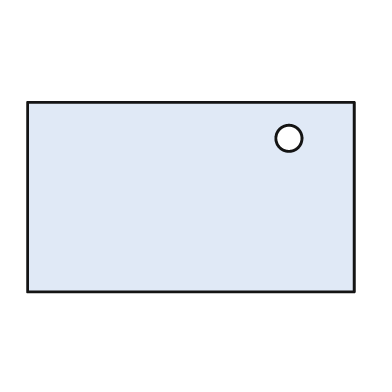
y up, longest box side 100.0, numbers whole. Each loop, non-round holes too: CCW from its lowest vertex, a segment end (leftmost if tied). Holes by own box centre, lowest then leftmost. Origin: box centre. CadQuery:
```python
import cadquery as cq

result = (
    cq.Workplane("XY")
    .moveTo(-50.0, -29.0)
    .lineTo(50.0, -29.0)
    .lineTo(50.0, 29.0)
    .lineTo(-50.0, 29.0)
    .close()
    .moveTo(30.0, 18.0)
    .circle(4.0)
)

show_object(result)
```